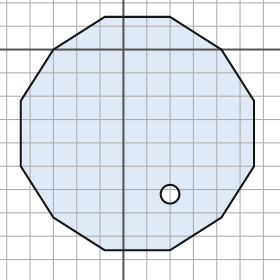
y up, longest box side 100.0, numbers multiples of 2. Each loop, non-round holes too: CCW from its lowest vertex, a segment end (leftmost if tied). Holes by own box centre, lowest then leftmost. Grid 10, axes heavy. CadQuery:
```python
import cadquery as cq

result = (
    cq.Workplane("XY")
    .moveTo(-8.0, -86.0)
    .lineTo(20.0, -86.0)
    .lineTo(42.0, -72.0)
    .lineTo(56.0, -50.0)
    .lineTo(56.0, -22.0)
    .lineTo(42.0, 0.0)
    .lineTo(20.0, 14.0)
    .lineTo(-8.0, 14.0)
    .lineTo(-30.0, 0.0)
    .lineTo(-44.0, -22.0)
    .lineTo(-44.0, -50.0)
    .lineTo(-30.0, -72.0)
    .close()
    .moveTo(20.0, -62.0)
    .circle(4.0)
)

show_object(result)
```